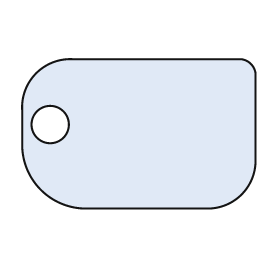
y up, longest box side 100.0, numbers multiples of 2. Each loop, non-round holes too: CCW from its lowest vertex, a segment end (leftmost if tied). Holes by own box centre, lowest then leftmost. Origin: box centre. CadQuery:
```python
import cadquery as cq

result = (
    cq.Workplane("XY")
    .moveTo(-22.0, -32.0)
    .lineTo(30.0, -32.0)
    .threePointArc((44.0, -26.0), (50.0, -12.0))
    .lineTo(50.0, 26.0)
    .threePointArc((48.0, 30.0), (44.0, 32.0))
    .lineTo(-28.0, 32.0)
    .threePointArc((-44.0, 26.0), (-50.0, 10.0))
    .lineTo(-50.0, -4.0)
    .threePointArc((-42.0, -24.0), (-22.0, -32.0))
    .close()
    .moveTo(-38.0, 4.0)
    .circle(8.0)
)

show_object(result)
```